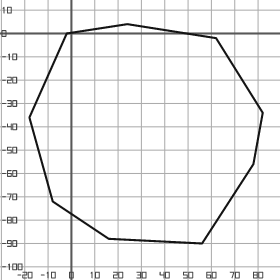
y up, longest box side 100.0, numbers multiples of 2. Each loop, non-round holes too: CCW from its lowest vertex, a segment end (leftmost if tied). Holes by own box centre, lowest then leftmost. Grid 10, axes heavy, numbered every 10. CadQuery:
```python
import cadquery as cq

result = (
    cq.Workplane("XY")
    .moveTo(56.0, -90.0)
    .lineTo(78.0, -56.0)
    .lineTo(82.0, -34.0)
    .lineTo(62.0, -2.0)
    .lineTo(24.0, 4.0)
    .lineTo(-2.0, 0.0)
    .lineTo(-18.0, -36.0)
    .lineTo(-8.0, -72.0)
    .lineTo(16.0, -88.0)
    .close()
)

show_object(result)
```